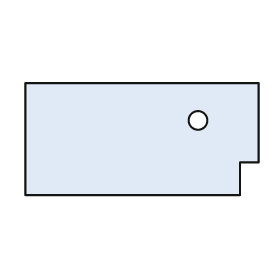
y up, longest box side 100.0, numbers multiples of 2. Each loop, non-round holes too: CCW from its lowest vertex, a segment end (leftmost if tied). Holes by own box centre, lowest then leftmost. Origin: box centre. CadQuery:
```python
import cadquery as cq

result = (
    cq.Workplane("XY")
    .moveTo(-50.0, -24.0)
    .lineTo(42.0, -24.0)
    .lineTo(42.0, -10.0)
    .lineTo(50.0, -10.0)
    .lineTo(50.0, 24.0)
    .lineTo(-50.0, 24.0)
    .close()
    .moveTo(24.0, 8.0)
    .circle(4.0)
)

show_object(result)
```